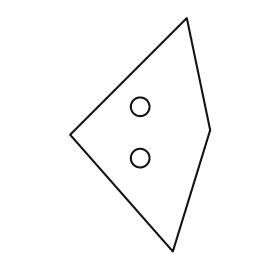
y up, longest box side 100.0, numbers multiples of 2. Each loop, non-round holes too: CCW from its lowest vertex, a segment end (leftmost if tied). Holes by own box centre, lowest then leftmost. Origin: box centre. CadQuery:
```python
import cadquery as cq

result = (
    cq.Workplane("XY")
    .moveTo(14.0, -50.0)
    .lineTo(30.0, 2.0)
    .lineTo(20.0, 50.0)
    .lineTo(-30.0, 0.0)
    .close()
    .moveTo(0.0, -10.0)
    .circle(4.0)
    .moveTo(0.0, 12.0)
    .circle(4.0)
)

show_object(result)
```